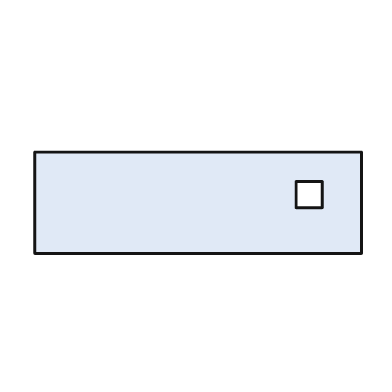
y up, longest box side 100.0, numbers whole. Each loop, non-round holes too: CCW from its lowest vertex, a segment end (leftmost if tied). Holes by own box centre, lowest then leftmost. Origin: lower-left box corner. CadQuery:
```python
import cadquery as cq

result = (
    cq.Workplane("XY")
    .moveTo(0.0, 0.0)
    .lineTo(100.0, 0.0)
    .lineTo(100.0, 31.0)
    .lineTo(0.0, 31.0)
    .close()
    .moveTo(80.0, 14.0)
    .lineTo(88.0, 14.0)
    .lineTo(88.0, 22.0)
    .lineTo(80.0, 22.0)
    .close()
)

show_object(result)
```